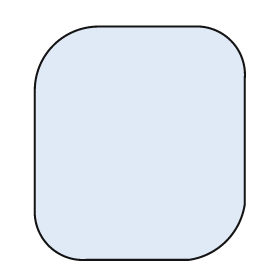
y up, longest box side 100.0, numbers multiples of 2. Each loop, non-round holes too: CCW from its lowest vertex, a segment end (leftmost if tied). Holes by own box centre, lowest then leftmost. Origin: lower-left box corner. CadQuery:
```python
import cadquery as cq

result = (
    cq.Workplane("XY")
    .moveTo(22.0, 0.0)
    .lineTo(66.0, 0.0)
    .threePointArc((82.0, 8.0), (90.0, 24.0))
    .lineTo(90.0, 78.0)
    .threePointArc((84.0, 94.0), (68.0, 100.0))
    .lineTo(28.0, 100.0)
    .threePointArc((8.0, 92.0), (0.0, 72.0))
    .lineTo(0.0, 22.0)
    .threePointArc((6.0, 6.0), (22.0, 0.0))
    .close()
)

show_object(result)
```